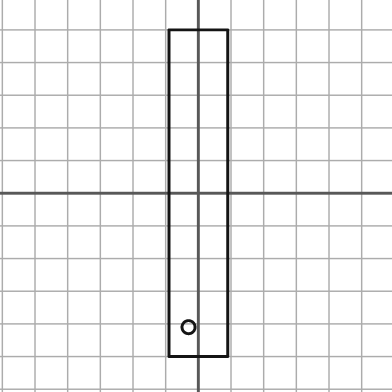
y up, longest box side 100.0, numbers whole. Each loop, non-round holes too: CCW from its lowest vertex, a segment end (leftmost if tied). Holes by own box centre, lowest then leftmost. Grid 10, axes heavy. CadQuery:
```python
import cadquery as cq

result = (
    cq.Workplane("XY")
    .moveTo(-9.0, -50.0)
    .lineTo(9.0, -50.0)
    .lineTo(9.0, 50.0)
    .lineTo(-9.0, 50.0)
    .close()
    .moveTo(-3.0, -41.0)
    .circle(2.0)
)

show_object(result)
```